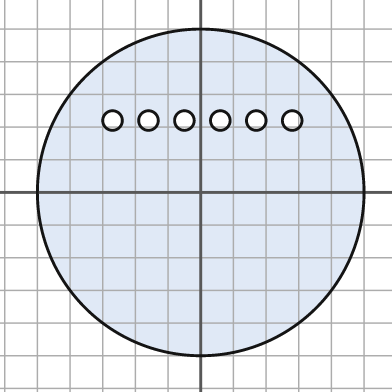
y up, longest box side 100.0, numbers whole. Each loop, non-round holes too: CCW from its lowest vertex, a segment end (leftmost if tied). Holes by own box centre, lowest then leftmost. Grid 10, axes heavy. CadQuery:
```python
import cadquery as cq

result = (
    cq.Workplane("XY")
    .moveTo(0.0, 0.0)
    .circle(50.0)
    .moveTo(-27.0, 22.0)
    .circle(3.0)
    .moveTo(-16.0, 22.0)
    .circle(3.0)
    .moveTo(-5.0, 22.0)
    .circle(3.0)
    .moveTo(6.0, 22.0)
    .circle(3.0)
    .moveTo(17.0, 22.0)
    .circle(3.0)
    .moveTo(28.0, 22.0)
    .circle(3.0)
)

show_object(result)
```